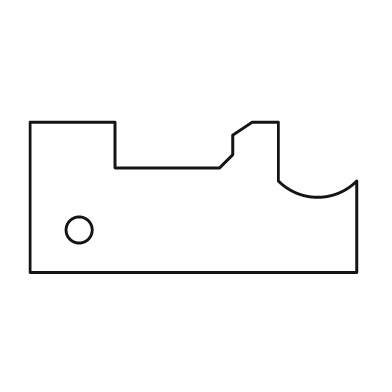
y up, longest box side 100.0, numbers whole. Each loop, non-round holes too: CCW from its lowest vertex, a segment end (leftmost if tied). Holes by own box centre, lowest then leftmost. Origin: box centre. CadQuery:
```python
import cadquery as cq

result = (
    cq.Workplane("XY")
    .moveTo(-50.0, -23.0)
    .lineTo(50.0, -23.0)
    .lineTo(50.0, 5.0)
    .threePointArc((38.0, 0.0), (26.0, 5.0))
    .lineTo(26.0, 23.0)
    .lineTo(18.0, 23.0)
    .lineTo(12.0, 19.0)
    .lineTo(12.0, 13.0)
    .lineTo(8.0, 9.0)
    .lineTo(-24.0, 9.0)
    .lineTo(-24.0, 23.0)
    .lineTo(-50.0, 23.0)
    .close()
    .moveTo(-35.0, -10.0)
    .circle(4.0)
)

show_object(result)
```